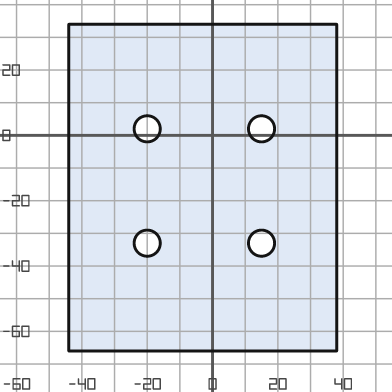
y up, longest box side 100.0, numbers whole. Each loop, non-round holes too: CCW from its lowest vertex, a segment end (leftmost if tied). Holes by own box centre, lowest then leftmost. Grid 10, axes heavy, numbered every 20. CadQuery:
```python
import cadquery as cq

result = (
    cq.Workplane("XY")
    .moveTo(-44.0, -66.0)
    .lineTo(38.0, -66.0)
    .lineTo(38.0, 34.0)
    .lineTo(-44.0, 34.0)
    .close()
    .moveTo(-20.0, -33.0)
    .circle(4.0)
    .moveTo(15.0, -33.0)
    .circle(4.0)
    .moveTo(-20.0, 2.0)
    .circle(4.0)
    .moveTo(15.0, 2.0)
    .circle(4.0)
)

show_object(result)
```